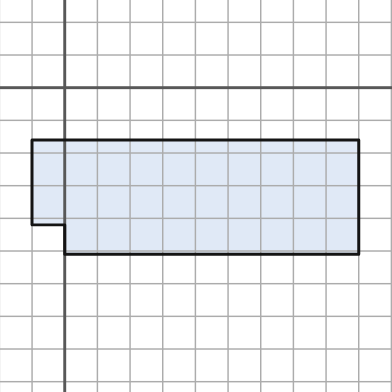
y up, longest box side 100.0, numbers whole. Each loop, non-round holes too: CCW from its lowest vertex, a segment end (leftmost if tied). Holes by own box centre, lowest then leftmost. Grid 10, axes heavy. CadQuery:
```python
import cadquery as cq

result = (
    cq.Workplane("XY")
    .moveTo(0.0, -51.0)
    .lineTo(90.0, -51.0)
    .lineTo(90.0, -16.0)
    .lineTo(-10.0, -16.0)
    .lineTo(-10.0, -42.0)
    .lineTo(0.0, -42.0)
    .close()
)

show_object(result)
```